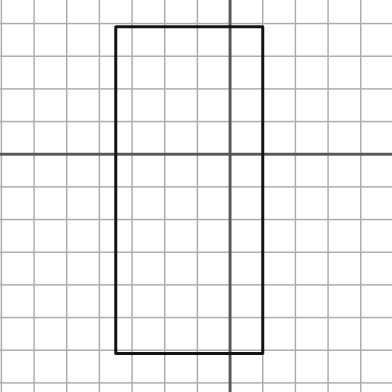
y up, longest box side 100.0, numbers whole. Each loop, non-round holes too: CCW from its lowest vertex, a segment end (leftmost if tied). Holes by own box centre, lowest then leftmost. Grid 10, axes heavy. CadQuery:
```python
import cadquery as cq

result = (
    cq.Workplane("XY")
    .moveTo(-35.0, -61.0)
    .lineTo(10.0, -61.0)
    .lineTo(10.0, 39.0)
    .lineTo(-35.0, 39.0)
    .close()
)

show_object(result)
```